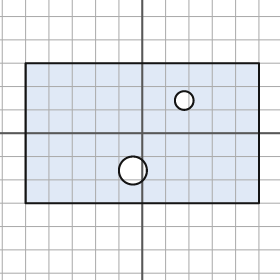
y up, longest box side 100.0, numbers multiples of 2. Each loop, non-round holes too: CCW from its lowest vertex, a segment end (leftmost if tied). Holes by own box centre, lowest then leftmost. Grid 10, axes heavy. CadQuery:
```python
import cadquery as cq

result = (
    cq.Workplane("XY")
    .moveTo(-50.0, -30.0)
    .lineTo(50.0, -30.0)
    .lineTo(50.0, 30.0)
    .lineTo(-50.0, 30.0)
    .close()
    .moveTo(-4.0, -16.0)
    .circle(6.0)
    .moveTo(18.0, 14.0)
    .circle(4.0)
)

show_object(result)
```